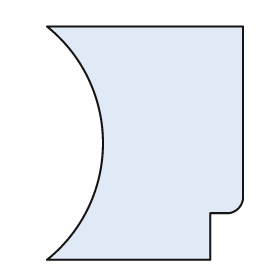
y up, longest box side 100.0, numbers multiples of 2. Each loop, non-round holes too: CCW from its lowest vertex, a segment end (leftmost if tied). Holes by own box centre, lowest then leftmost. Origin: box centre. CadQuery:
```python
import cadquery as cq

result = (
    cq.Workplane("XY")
    .moveTo(-42.0, -50.0)
    .lineTo(28.0, -50.0)
    .lineTo(28.0, -30.0)
    .lineTo(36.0, -30.0)
    .threePointArc((40.0, -28.0), (42.0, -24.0))
    .lineTo(42.0, 50.0)
    .lineTo(-42.0, 50.0)
    .threePointArc((-18.0, 0.0), (-42.0, -50.0))
    .close()
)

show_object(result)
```